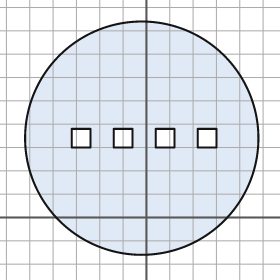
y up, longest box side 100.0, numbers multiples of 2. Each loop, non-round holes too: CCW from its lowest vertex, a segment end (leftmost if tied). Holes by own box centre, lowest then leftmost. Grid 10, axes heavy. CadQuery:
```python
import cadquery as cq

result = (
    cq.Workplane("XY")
    .moveTo(-2.0, 34.0)
    .circle(50.0)
    .moveTo(-32.0, 30.0)
    .lineTo(-24.0, 30.0)
    .lineTo(-24.0, 38.0)
    .lineTo(-32.0, 38.0)
    .close()
    .moveTo(-14.0, 30.0)
    .lineTo(-6.0, 30.0)
    .lineTo(-6.0, 38.0)
    .lineTo(-14.0, 38.0)
    .close()
    .moveTo(4.0, 30.0)
    .lineTo(12.0, 30.0)
    .lineTo(12.0, 38.0)
    .lineTo(4.0, 38.0)
    .close()
    .moveTo(22.0, 30.0)
    .lineTo(30.0, 30.0)
    .lineTo(30.0, 38.0)
    .lineTo(22.0, 38.0)
    .close()
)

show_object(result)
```